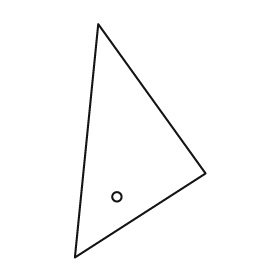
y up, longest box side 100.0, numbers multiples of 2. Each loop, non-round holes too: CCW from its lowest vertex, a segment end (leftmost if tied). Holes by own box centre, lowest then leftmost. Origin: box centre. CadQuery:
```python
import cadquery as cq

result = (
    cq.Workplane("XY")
    .moveTo(-28.0, -50.0)
    .lineTo(28.0, -14.0)
    .lineTo(-18.0, 50.0)
    .close()
    .moveTo(-10.0, -24.0)
    .circle(2.0)
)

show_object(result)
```